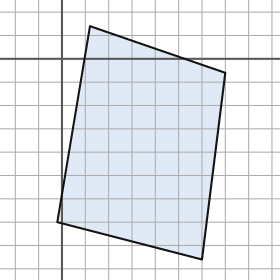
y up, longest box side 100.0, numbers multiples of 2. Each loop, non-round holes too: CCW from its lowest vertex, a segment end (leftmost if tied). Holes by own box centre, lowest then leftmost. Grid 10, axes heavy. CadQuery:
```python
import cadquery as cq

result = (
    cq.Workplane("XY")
    .moveTo(60.0, -86.0)
    .lineTo(70.0, -6.0)
    .lineTo(12.0, 14.0)
    .lineTo(-2.0, -70.0)
    .close()
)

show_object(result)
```